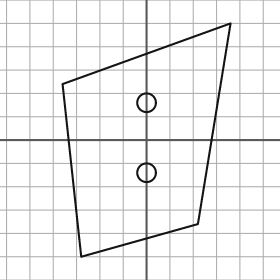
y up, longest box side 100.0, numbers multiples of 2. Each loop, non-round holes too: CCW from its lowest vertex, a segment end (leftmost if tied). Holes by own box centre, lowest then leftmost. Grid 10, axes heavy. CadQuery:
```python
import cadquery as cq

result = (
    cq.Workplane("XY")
    .moveTo(-28.0, -50.0)
    .lineTo(22.0, -36.0)
    .lineTo(36.0, 50.0)
    .lineTo(-36.0, 24.0)
    .close()
    .moveTo(0.0, -14.0)
    .circle(4.0)
    .moveTo(0.0, 16.0)
    .circle(4.0)
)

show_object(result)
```